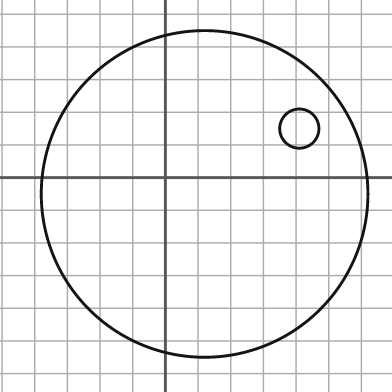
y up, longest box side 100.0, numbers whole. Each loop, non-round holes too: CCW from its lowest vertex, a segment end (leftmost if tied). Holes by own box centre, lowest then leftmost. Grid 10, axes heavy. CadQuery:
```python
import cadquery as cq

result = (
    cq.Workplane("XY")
    .moveTo(12.0, -5.0)
    .circle(50.0)
    .moveTo(41.0, 15.0)
    .circle(6.0)
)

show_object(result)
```